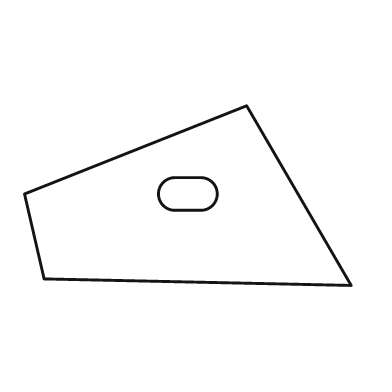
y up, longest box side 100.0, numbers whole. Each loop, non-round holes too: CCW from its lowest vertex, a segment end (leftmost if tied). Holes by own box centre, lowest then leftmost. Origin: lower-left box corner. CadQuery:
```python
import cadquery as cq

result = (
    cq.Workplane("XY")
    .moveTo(100.0, 0.0)
    .lineTo(68.0, 55.0)
    .lineTo(0.0, 28.0)
    .lineTo(6.0, 2.0)
    .close()
    .moveTo(46.0, 23.0)
    .lineTo(54.0, 23.0)
    .threePointArc((59.0, 28.0), (54.0, 33.0))
    .lineTo(46.0, 33.0)
    .threePointArc((41.0, 28.0), (46.0, 23.0))
    .close()
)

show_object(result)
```